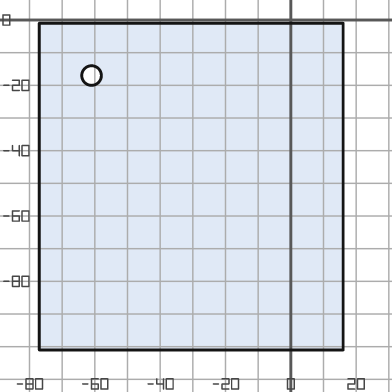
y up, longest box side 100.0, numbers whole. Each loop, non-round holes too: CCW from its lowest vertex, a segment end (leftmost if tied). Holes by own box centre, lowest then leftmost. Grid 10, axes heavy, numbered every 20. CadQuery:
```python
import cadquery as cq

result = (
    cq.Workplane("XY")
    .moveTo(-77.0, -101.0)
    .lineTo(16.0, -101.0)
    .lineTo(16.0, -1.0)
    .lineTo(-77.0, -1.0)
    .close()
    .moveTo(-61.0, -17.0)
    .circle(3.0)
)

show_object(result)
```